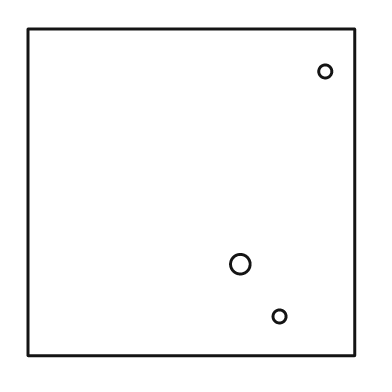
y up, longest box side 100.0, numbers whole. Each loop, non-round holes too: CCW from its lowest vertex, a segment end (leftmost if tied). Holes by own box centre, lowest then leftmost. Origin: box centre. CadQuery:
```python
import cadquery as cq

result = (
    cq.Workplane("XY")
    .moveTo(-50.0, -50.0)
    .lineTo(50.0, -50.0)
    .lineTo(50.0, 50.0)
    .lineTo(-50.0, 50.0)
    .close()
    .moveTo(27.0, -38.0)
    .circle(2.0)
    .moveTo(15.0, -22.0)
    .circle(3.0)
    .moveTo(41.0, 37.0)
    .circle(2.0)
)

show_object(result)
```